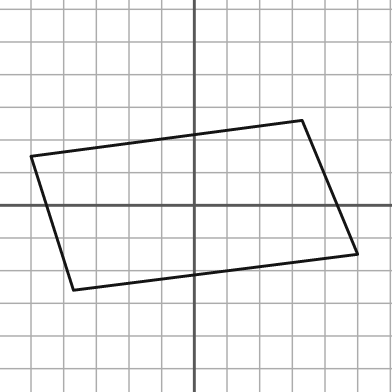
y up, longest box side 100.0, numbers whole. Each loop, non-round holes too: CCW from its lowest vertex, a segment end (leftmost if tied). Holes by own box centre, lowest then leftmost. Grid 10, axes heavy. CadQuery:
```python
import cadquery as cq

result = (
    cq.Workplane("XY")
    .moveTo(-37.0, -26.0)
    .lineTo(50.0, -15.0)
    .lineTo(33.0, 26.0)
    .lineTo(-50.0, 15.0)
    .close()
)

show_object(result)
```